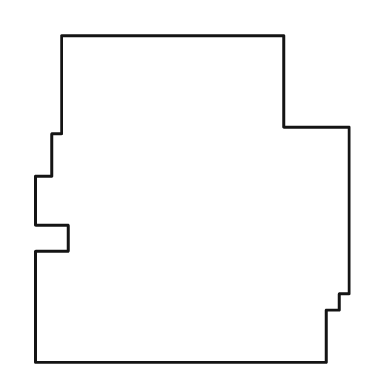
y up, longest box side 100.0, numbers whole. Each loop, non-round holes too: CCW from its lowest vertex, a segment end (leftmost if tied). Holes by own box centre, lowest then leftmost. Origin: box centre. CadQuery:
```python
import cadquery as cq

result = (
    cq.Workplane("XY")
    .moveTo(-48.0, -50.0)
    .lineTo(41.0, -50.0)
    .lineTo(41.0, -34.0)
    .lineTo(45.0, -34.0)
    .lineTo(45.0, -29.0)
    .lineTo(48.0, -29.0)
    .lineTo(48.0, 22.0)
    .lineTo(28.0, 22.0)
    .lineTo(28.0, 50.0)
    .lineTo(-40.0, 50.0)
    .lineTo(-40.0, 20.0)
    .lineTo(-43.0, 20.0)
    .lineTo(-43.0, 7.0)
    .lineTo(-48.0, 7.0)
    .lineTo(-48.0, -8.0)
    .lineTo(-38.0, -8.0)
    .lineTo(-38.0, -16.0)
    .lineTo(-48.0, -16.0)
    .close()
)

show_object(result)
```